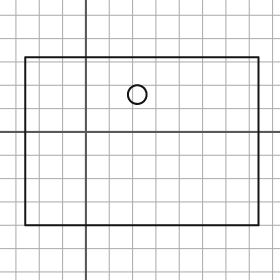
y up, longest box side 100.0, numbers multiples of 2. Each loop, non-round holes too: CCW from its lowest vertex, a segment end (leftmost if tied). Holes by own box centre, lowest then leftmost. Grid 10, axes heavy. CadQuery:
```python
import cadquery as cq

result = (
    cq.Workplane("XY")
    .moveTo(-26.0, -40.0)
    .lineTo(74.0, -40.0)
    .lineTo(74.0, 32.0)
    .lineTo(-26.0, 32.0)
    .close()
    .moveTo(22.0, 16.0)
    .circle(4.0)
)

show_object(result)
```